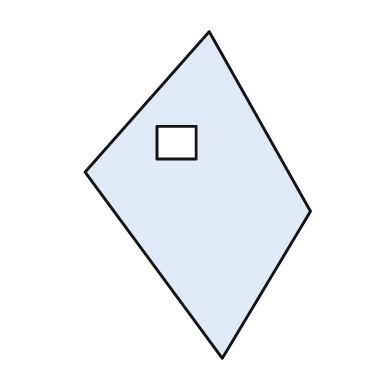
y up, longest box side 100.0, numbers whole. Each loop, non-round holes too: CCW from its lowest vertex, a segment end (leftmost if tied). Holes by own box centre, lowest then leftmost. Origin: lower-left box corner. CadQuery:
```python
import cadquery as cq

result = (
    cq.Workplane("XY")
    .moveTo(42.0, 0.0)
    .lineTo(69.0, 45.0)
    .lineTo(38.0, 100.0)
    .lineTo(0.0, 57.0)
    .close()
    .moveTo(22.0, 61.0)
    .lineTo(34.0, 61.0)
    .lineTo(34.0, 71.0)
    .lineTo(22.0, 71.0)
    .close()
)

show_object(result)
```